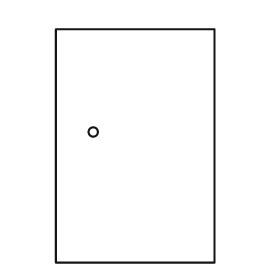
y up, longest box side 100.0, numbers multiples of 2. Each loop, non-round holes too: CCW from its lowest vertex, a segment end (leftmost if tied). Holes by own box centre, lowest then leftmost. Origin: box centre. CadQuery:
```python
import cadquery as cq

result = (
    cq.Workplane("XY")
    .moveTo(-34.0, -50.0)
    .lineTo(34.0, -50.0)
    .lineTo(34.0, 50.0)
    .lineTo(-34.0, 50.0)
    .close()
    .moveTo(-18.0, 6.0)
    .circle(2.0)
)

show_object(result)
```